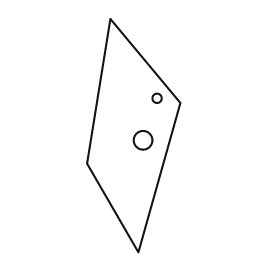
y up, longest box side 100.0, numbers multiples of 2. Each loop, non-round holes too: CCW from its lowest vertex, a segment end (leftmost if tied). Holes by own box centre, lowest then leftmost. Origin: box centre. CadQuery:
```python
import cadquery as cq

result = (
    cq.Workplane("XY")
    .moveTo(2.0, -50.0)
    .lineTo(20.0, 14.0)
    .lineTo(-10.0, 50.0)
    .lineTo(-20.0, -12.0)
    .close()
    .moveTo(4.0, -2.0)
    .circle(4.0)
    .moveTo(10.0, 16.0)
    .circle(2.0)
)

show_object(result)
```